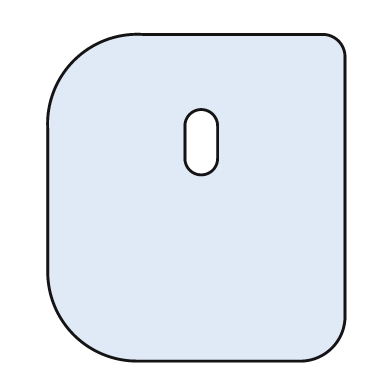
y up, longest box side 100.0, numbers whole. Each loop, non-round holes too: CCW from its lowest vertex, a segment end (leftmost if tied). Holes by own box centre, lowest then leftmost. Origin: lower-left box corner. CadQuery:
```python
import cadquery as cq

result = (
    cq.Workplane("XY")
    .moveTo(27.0, 0.0)
    .lineTo(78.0, 0.0)
    .threePointArc((87.0, 4.0), (91.0, 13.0))
    .lineTo(91.0, 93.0)
    .threePointArc((89.0, 98.0), (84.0, 100.0))
    .lineTo(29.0, 100.0)
    .threePointArc((8.0, 92.0), (0.0, 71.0))
    .lineTo(0.0, 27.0)
    .threePointArc((8.0, 8.0), (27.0, 0.0))
    .close()
    .moveTo(42.0, 62.0)
    .threePointArc((47.0, 57.0), (52.0, 62.0))
    .lineTo(52.0, 72.0)
    .threePointArc((47.0, 77.0), (42.0, 72.0))
    .close()
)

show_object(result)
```